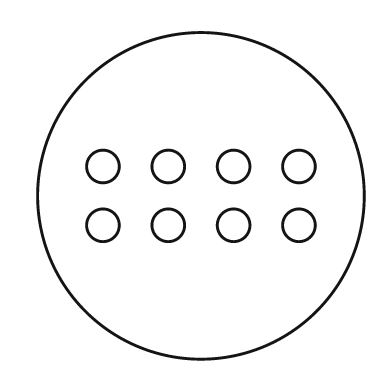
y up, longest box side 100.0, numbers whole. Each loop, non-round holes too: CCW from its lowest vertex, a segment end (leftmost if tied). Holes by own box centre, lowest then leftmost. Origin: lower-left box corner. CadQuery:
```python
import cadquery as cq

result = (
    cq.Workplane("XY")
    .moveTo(50.0, 50.0)
    .circle(50.0)
    .moveTo(20.0, 41.0)
    .circle(5.0)
    .moveTo(40.0, 41.0)
    .circle(5.0)
    .moveTo(60.0, 41.0)
    .circle(5.0)
    .moveTo(80.0, 41.0)
    .circle(5.0)
    .moveTo(20.0, 59.0)
    .circle(5.0)
    .moveTo(40.0, 59.0)
    .circle(5.0)
    .moveTo(60.0, 59.0)
    .circle(5.0)
    .moveTo(80.0, 59.0)
    .circle(5.0)
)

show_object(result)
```